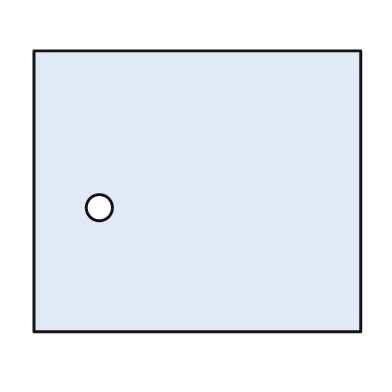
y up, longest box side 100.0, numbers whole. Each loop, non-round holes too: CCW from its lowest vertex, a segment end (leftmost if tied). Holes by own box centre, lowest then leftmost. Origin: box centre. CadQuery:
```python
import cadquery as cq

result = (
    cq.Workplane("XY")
    .moveTo(-50.0, -43.0)
    .lineTo(50.0, -43.0)
    .lineTo(50.0, 43.0)
    .lineTo(-50.0, 43.0)
    .close()
    .moveTo(-30.0, -5.0)
    .circle(4.0)
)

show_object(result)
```